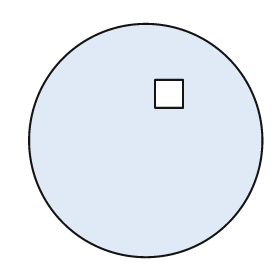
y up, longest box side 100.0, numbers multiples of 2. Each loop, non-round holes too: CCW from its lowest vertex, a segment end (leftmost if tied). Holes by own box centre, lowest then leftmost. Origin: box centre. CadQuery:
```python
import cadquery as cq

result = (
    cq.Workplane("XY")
    .moveTo(0.0, 0.0)
    .circle(50.0)
    .moveTo(4.0, 14.0)
    .lineTo(16.0, 14.0)
    .lineTo(16.0, 26.0)
    .lineTo(4.0, 26.0)
    .close()
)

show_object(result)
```